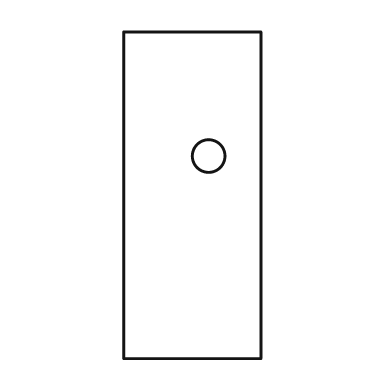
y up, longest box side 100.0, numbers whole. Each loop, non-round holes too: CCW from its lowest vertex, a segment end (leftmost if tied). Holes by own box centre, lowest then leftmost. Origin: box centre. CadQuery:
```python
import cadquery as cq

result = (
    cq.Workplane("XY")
    .moveTo(-21.0, -50.0)
    .lineTo(21.0, -50.0)
    .lineTo(21.0, 50.0)
    .lineTo(-21.0, 50.0)
    .close()
    .moveTo(5.0, 12.0)
    .circle(5.0)
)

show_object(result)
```